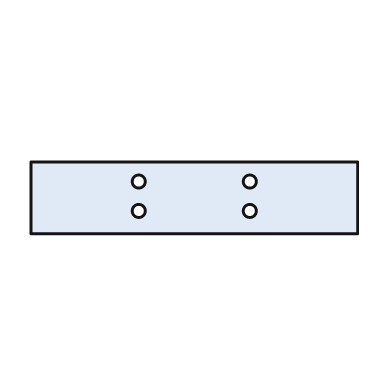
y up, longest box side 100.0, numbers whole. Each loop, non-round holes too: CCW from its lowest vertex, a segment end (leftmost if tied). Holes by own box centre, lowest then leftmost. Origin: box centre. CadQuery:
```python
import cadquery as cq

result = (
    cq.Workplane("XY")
    .moveTo(-50.0, -11.0)
    .lineTo(50.0, -11.0)
    .lineTo(50.0, 11.0)
    .lineTo(-50.0, 11.0)
    .close()
    .moveTo(-17.0, -4.0)
    .circle(2.0)
    .moveTo(17.0, -4.0)
    .circle(2.0)
    .moveTo(-17.0, 5.0)
    .circle(2.0)
    .moveTo(17.0, 5.0)
    .circle(2.0)
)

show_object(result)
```